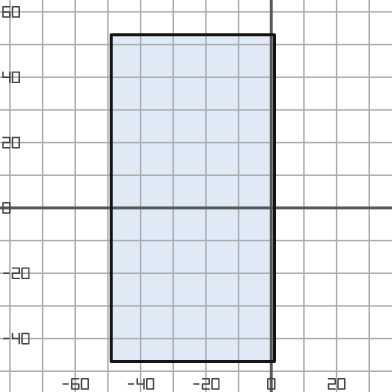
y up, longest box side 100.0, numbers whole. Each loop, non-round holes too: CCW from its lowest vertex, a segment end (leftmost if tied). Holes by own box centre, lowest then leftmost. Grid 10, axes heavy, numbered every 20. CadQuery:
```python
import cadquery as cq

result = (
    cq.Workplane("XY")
    .moveTo(-49.0, -47.0)
    .lineTo(1.0, -47.0)
    .lineTo(1.0, 53.0)
    .lineTo(-49.0, 53.0)
    .close()
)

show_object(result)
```